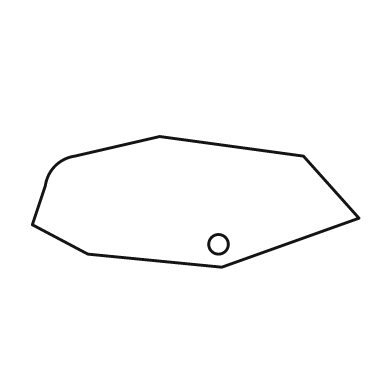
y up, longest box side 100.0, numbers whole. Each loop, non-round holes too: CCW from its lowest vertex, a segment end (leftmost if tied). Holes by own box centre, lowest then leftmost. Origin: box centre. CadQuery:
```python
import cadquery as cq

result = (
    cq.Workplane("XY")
    .moveTo(8.0, -20.0)
    .lineTo(50.0, -5.0)
    .lineTo(33.0, 14.0)
    .lineTo(-11.0, 20.0)
    .lineTo(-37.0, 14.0)
    .threePointArc((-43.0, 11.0), (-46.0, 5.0))
    .lineTo(-50.0, -7.0)
    .lineTo(-33.0, -16.0)
    .close()
    .moveTo(7.0, -13.0)
    .circle(3.0)
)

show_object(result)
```